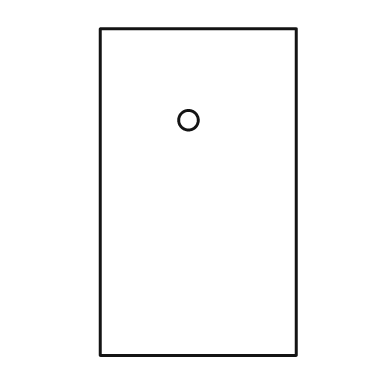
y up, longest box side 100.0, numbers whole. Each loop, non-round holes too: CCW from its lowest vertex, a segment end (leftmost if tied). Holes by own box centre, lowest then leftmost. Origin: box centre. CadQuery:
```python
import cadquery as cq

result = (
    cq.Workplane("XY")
    .moveTo(-30.0, -50.0)
    .lineTo(30.0, -50.0)
    .lineTo(30.0, 50.0)
    .lineTo(-30.0, 50.0)
    .close()
    .moveTo(-3.0, 22.0)
    .circle(3.0)
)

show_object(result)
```